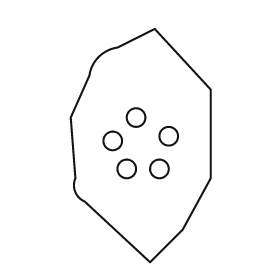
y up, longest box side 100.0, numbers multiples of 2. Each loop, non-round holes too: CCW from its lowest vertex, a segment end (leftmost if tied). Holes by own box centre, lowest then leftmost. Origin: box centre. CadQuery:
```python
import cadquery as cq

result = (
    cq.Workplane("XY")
    .moveTo(4.0, -50.0)
    .lineTo(18.0, -36.0)
    .lineTo(30.0, -14.0)
    .lineTo(30.0, 24.0)
    .lineTo(6.0, 50.0)
    .lineTo(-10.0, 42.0)
    .threePointArc((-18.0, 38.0), (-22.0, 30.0))
    .lineTo(-30.0, 12.0)
    .lineTo(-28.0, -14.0)
    .threePointArc((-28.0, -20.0), (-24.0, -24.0))
    .close()
    .moveTo(-6.0, -10.0)
    .circle(4.0)
    .moveTo(8.0, -10.0)
    .circle(4.0)
    .moveTo(-12.0, 2.0)
    .circle(4.0)
    .moveTo(12.0, 4.0)
    .circle(4.0)
    .moveTo(-2.0, 12.0)
    .circle(4.0)
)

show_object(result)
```